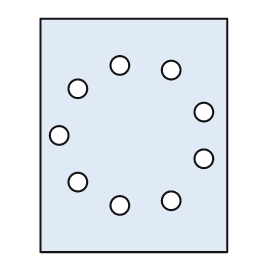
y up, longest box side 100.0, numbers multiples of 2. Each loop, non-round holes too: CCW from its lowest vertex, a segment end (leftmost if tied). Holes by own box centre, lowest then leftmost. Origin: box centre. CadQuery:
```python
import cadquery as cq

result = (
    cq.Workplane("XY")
    .moveTo(-40.0, -50.0)
    .lineTo(40.0, -50.0)
    .lineTo(40.0, 50.0)
    .lineTo(-40.0, 50.0)
    .close()
    .moveTo(-6.0, -30.0)
    .circle(4.0)
    .moveTo(16.0, -28.0)
    .circle(4.0)
    .moveTo(-24.0, -20.0)
    .circle(4.0)
    .moveTo(30.0, -10.0)
    .circle(4.0)
    .moveTo(-32.0, 0.0)
    .circle(4.0)
    .moveTo(30.0, 10.0)
    .circle(4.0)
    .moveTo(-24.0, 20.0)
    .circle(4.0)
    .moveTo(16.0, 28.0)
    .circle(4.0)
    .moveTo(-6.0, 30.0)
    .circle(4.0)
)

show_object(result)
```